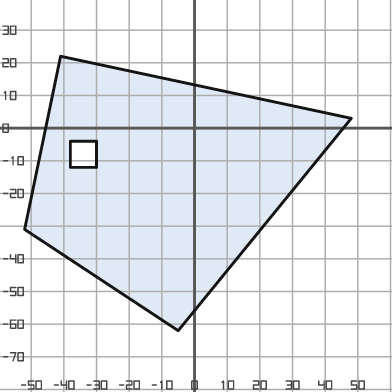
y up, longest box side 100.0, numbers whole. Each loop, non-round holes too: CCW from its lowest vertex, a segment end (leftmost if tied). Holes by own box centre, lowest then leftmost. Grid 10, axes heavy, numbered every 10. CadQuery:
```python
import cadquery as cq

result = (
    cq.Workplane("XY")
    .moveTo(-5.0, -62.0)
    .lineTo(48.0, 3.0)
    .lineTo(-41.0, 22.0)
    .lineTo(-52.0, -31.0)
    .close()
    .moveTo(-38.0, -12.0)
    .lineTo(-30.0, -12.0)
    .lineTo(-30.0, -4.0)
    .lineTo(-38.0, -4.0)
    .close()
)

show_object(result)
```